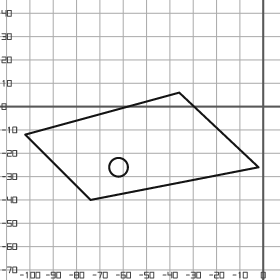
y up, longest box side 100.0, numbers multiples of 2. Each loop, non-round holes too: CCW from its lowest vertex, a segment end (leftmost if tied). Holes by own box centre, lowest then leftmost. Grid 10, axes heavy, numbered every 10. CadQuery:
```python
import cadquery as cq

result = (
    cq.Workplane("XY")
    .moveTo(-74.0, -40.0)
    .lineTo(-2.0, -26.0)
    .lineTo(-36.0, 6.0)
    .lineTo(-102.0, -12.0)
    .close()
    .moveTo(-62.0, -26.0)
    .circle(4.0)
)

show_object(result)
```